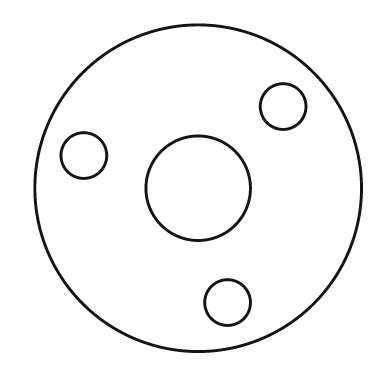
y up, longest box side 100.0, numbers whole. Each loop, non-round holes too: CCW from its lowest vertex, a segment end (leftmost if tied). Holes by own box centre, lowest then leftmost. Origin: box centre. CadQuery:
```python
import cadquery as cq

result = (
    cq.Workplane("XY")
    .moveTo(0.0, 0.0)
    .circle(50.0)
    .moveTo(9.0, -35.0)
    .circle(7.0)
    .moveTo(0.0, 0.0)
    .circle(16.0)
    .moveTo(-35.0, 10.0)
    .circle(7.0)
    .moveTo(26.0, 25.0)
    .circle(7.0)
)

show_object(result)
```